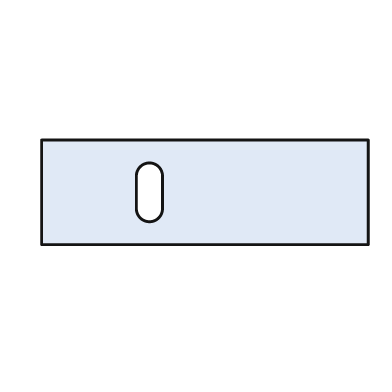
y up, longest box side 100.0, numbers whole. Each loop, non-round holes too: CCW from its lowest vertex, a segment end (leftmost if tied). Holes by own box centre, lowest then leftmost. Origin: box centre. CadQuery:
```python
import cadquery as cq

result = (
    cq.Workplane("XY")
    .moveTo(-50.0, -16.0)
    .lineTo(50.0, -16.0)
    .lineTo(50.0, 16.0)
    .lineTo(-50.0, 16.0)
    .close()
    .moveTo(-21.0, -5.0)
    .threePointArc((-17.0, -9.0), (-13.0, -5.0))
    .lineTo(-13.0, 5.0)
    .threePointArc((-17.0, 9.0), (-21.0, 5.0))
    .close()
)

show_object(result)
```